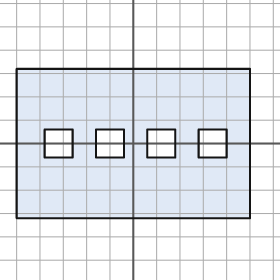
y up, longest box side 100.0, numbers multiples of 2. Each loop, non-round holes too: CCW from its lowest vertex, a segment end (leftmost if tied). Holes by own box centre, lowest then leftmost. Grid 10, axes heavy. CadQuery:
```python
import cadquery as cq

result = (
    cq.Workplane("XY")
    .moveTo(-50.0, -32.0)
    .lineTo(50.0, -32.0)
    .lineTo(50.0, 32.0)
    .lineTo(-50.0, 32.0)
    .close()
    .moveTo(-38.0, -6.0)
    .lineTo(-26.0, -6.0)
    .lineTo(-26.0, 6.0)
    .lineTo(-38.0, 6.0)
    .close()
    .moveTo(-16.0, -6.0)
    .lineTo(-4.0, -6.0)
    .lineTo(-4.0, 6.0)
    .lineTo(-16.0, 6.0)
    .close()
    .moveTo(6.0, -6.0)
    .lineTo(18.0, -6.0)
    .lineTo(18.0, 6.0)
    .lineTo(6.0, 6.0)
    .close()
    .moveTo(28.0, -6.0)
    .lineTo(40.0, -6.0)
    .lineTo(40.0, 6.0)
    .lineTo(28.0, 6.0)
    .close()
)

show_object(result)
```